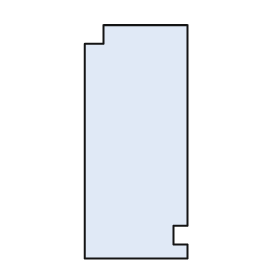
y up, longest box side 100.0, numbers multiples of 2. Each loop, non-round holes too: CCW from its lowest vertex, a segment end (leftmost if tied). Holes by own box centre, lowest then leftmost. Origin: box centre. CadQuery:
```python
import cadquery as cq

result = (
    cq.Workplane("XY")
    .moveTo(-22.0, -50.0)
    .lineTo(22.0, -50.0)
    .lineTo(22.0, -44.0)
    .lineTo(16.0, -44.0)
    .lineTo(16.0, -36.0)
    .lineTo(22.0, -36.0)
    .lineTo(22.0, 50.0)
    .lineTo(-14.0, 50.0)
    .lineTo(-14.0, 42.0)
    .lineTo(-22.0, 42.0)
    .close()
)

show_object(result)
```